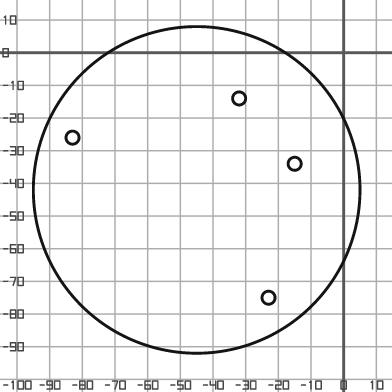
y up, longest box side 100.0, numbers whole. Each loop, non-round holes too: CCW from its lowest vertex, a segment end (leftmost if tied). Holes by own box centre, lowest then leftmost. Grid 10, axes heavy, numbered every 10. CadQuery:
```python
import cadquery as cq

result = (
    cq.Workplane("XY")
    .moveTo(-45.0, -42.0)
    .circle(50.0)
    .moveTo(-23.0, -75.0)
    .circle(2.0)
    .moveTo(-15.0, -34.0)
    .circle(2.0)
    .moveTo(-83.0, -26.0)
    .circle(2.0)
    .moveTo(-32.0, -14.0)
    .circle(2.0)
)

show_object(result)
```